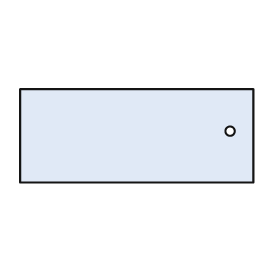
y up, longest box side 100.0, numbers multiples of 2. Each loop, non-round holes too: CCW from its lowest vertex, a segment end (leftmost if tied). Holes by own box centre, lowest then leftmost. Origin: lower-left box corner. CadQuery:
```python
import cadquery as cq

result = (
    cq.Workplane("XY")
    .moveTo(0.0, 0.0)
    .lineTo(100.0, 0.0)
    .lineTo(100.0, 40.0)
    .lineTo(0.0, 40.0)
    .close()
    .moveTo(90.0, 22.0)
    .circle(2.0)
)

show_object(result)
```